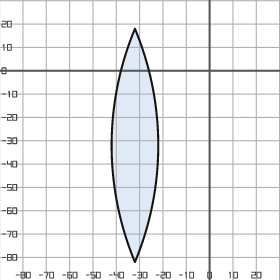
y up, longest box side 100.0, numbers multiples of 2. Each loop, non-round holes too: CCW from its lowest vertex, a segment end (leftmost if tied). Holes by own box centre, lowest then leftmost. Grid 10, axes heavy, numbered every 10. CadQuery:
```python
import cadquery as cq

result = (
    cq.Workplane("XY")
    .moveTo(-32.0, -82.0)
    .threePointArc((-22.0, -32.0), (-32.0, 18.0))
    .threePointArc((-42.0, -32.0), (-32.0, -82.0))
    .close()
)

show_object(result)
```